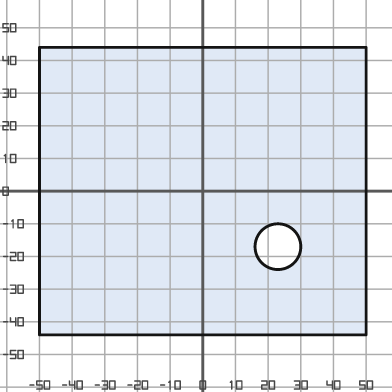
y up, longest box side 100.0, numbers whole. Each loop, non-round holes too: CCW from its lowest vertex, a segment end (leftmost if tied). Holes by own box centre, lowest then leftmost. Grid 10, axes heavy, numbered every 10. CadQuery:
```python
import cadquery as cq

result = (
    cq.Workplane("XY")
    .moveTo(-50.0, -44.0)
    .lineTo(50.0, -44.0)
    .lineTo(50.0, 44.0)
    .lineTo(-50.0, 44.0)
    .close()
    .moveTo(23.0, -17.0)
    .circle(7.0)
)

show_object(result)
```